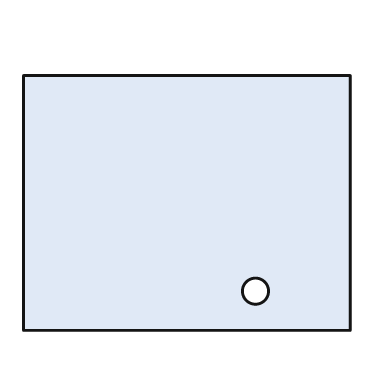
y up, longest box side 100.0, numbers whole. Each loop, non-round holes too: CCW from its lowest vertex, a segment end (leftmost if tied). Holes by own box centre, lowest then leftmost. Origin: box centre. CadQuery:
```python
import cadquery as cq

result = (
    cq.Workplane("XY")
    .moveTo(-50.0, -39.0)
    .lineTo(50.0, -39.0)
    .lineTo(50.0, 39.0)
    .lineTo(-50.0, 39.0)
    .close()
    .moveTo(21.0, -27.0)
    .circle(4.0)
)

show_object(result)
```